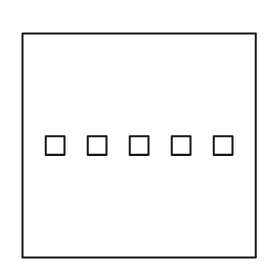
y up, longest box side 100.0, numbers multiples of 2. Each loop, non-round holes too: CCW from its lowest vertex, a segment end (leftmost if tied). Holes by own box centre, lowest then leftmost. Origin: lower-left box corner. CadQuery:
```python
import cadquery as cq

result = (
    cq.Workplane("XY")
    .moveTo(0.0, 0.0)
    .lineTo(100.0, 0.0)
    .lineTo(100.0, 96.0)
    .lineTo(0.0, 96.0)
    .close()
    .moveTo(10.0, 44.0)
    .lineTo(18.0, 44.0)
    .lineTo(18.0, 52.0)
    .lineTo(10.0, 52.0)
    .close()
    .moveTo(28.0, 44.0)
    .lineTo(36.0, 44.0)
    .lineTo(36.0, 52.0)
    .lineTo(28.0, 52.0)
    .close()
    .moveTo(46.0, 44.0)
    .lineTo(54.0, 44.0)
    .lineTo(54.0, 52.0)
    .lineTo(46.0, 52.0)
    .close()
    .moveTo(64.0, 44.0)
    .lineTo(72.0, 44.0)
    .lineTo(72.0, 52.0)
    .lineTo(64.0, 52.0)
    .close()
    .moveTo(82.0, 44.0)
    .lineTo(90.0, 44.0)
    .lineTo(90.0, 52.0)
    .lineTo(82.0, 52.0)
    .close()
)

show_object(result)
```